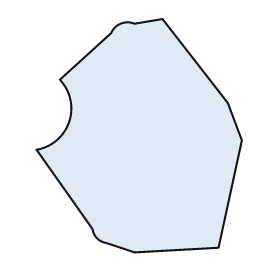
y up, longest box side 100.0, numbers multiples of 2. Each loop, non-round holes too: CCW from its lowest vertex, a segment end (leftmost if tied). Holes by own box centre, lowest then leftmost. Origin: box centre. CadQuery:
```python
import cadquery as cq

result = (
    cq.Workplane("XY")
    .moveTo(-2.0, -50.0)
    .lineTo(34.0, -48.0)
    .lineTo(44.0, -2.0)
    .lineTo(38.0, 14.0)
    .lineTo(10.0, 50.0)
    .lineTo(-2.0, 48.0)
    .threePointArc((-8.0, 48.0), (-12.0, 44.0))
    .lineTo(-34.0, 24.0)
    .threePointArc((-30.0, 6.0), (-44.0, -6.0))
    .lineTo(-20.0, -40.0)
    .threePointArc((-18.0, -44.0), (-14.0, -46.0))
    .close()
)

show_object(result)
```